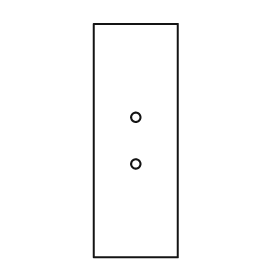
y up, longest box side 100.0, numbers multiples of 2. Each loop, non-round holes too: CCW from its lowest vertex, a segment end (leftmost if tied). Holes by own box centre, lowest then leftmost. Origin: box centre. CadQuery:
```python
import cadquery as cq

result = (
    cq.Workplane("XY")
    .moveTo(-18.0, -50.0)
    .lineTo(18.0, -50.0)
    .lineTo(18.0, 50.0)
    .lineTo(-18.0, 50.0)
    .close()
    .moveTo(0.0, -10.0)
    .circle(2.0)
    .moveTo(0.0, 10.0)
    .circle(2.0)
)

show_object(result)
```